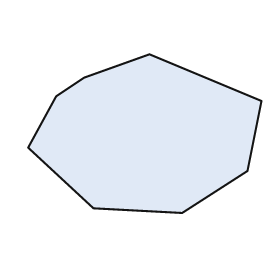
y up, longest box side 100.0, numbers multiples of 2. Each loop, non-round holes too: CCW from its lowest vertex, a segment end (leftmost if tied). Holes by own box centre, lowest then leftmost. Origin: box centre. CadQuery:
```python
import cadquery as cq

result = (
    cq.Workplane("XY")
    .moveTo(16.0, -34.0)
    .lineTo(44.0, -16.0)
    .lineTo(50.0, 14.0)
    .lineTo(2.0, 34.0)
    .lineTo(-26.0, 24.0)
    .lineTo(-38.0, 16.0)
    .lineTo(-50.0, -6.0)
    .lineTo(-22.0, -32.0)
    .close()
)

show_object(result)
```